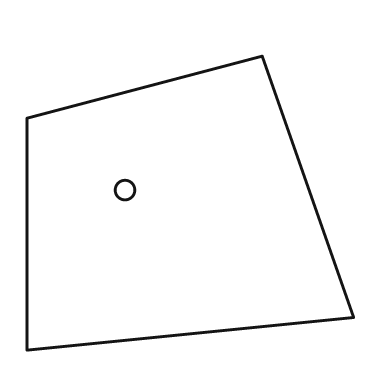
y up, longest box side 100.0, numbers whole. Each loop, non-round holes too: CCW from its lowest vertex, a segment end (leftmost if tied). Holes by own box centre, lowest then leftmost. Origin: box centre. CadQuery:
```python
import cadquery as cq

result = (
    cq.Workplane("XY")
    .moveTo(-50.0, -45.0)
    .lineTo(50.0, -35.0)
    .lineTo(22.0, 45.0)
    .lineTo(-50.0, 26.0)
    .close()
    .moveTo(-20.0, 4.0)
    .circle(3.0)
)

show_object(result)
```